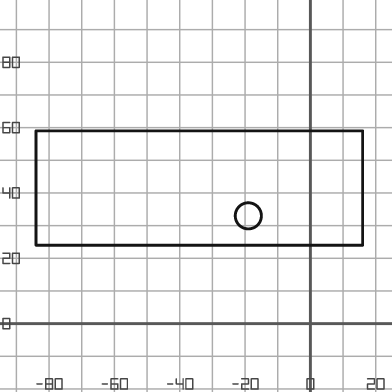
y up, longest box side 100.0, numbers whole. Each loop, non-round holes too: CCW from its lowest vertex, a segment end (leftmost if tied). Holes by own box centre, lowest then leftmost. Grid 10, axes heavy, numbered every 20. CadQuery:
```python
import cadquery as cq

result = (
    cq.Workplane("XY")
    .moveTo(-84.0, 24.0)
    .lineTo(16.0, 24.0)
    .lineTo(16.0, 59.0)
    .lineTo(-84.0, 59.0)
    .close()
    .moveTo(-19.0, 33.0)
    .circle(4.0)
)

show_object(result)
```